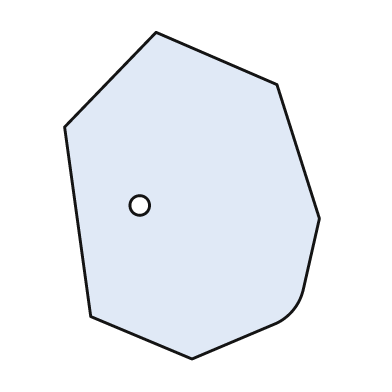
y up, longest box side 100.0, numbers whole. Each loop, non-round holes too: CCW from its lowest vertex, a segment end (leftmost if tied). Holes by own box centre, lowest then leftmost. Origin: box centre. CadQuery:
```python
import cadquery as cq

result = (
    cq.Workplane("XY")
    .moveTo(0.0, -50.0)
    .lineTo(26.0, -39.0)
    .threePointArc((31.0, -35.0), (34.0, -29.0))
    .lineTo(39.0, -7.0)
    .lineTo(26.0, 34.0)
    .lineTo(-11.0, 50.0)
    .lineTo(-39.0, 21.0)
    .lineTo(-31.0, -37.0)
    .close()
    .moveTo(-16.0, -3.0)
    .circle(3.0)
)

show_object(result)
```